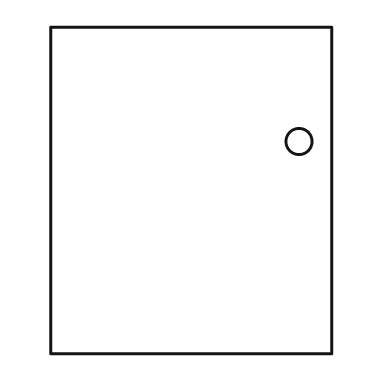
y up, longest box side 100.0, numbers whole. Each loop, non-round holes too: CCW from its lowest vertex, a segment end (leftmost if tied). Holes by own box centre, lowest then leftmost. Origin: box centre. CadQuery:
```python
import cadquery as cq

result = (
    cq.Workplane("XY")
    .moveTo(-43.0, -50.0)
    .lineTo(43.0, -50.0)
    .lineTo(43.0, 50.0)
    .lineTo(-43.0, 50.0)
    .close()
    .moveTo(33.0, 15.0)
    .circle(4.0)
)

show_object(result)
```